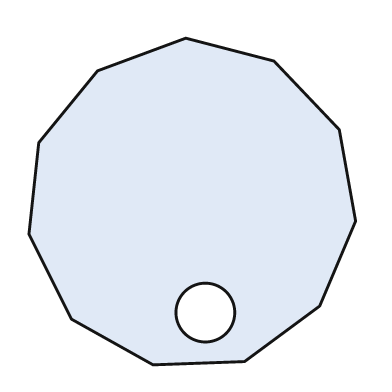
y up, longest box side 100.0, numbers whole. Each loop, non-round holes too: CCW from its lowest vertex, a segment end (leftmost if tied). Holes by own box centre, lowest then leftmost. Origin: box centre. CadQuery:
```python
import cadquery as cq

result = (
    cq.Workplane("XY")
    .moveTo(-12.0, -50.0)
    .lineTo(16.0, -49.0)
    .lineTo(39.0, -32.0)
    .lineTo(50.0, -6.0)
    .lineTo(45.0, 22.0)
    .lineTo(25.0, 43.0)
    .lineTo(-2.0, 50.0)
    .lineTo(-29.0, 40.0)
    .lineTo(-47.0, 18.0)
    .lineTo(-50.0, -10.0)
    .lineTo(-37.0, -36.0)
    .close()
    .moveTo(4.0, -34.0)
    .circle(9.0)
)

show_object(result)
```